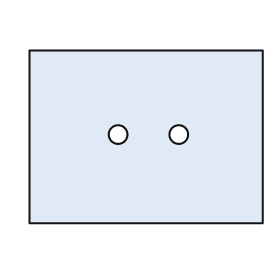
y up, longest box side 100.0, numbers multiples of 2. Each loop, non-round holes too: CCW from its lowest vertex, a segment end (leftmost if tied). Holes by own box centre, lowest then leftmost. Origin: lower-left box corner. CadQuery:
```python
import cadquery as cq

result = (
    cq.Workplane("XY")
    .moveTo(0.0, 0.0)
    .lineTo(100.0, 0.0)
    .lineTo(100.0, 74.0)
    .lineTo(0.0, 74.0)
    .close()
    .moveTo(38.0, 38.0)
    .circle(4.0)
    .moveTo(64.0, 38.0)
    .circle(4.0)
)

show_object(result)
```